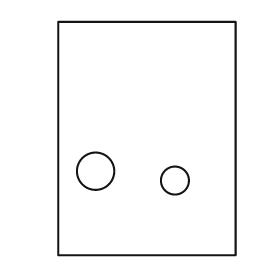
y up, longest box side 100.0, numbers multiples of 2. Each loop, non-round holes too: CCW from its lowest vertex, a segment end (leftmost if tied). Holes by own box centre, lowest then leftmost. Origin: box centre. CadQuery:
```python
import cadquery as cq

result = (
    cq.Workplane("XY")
    .moveTo(-38.0, -50.0)
    .lineTo(38.0, -50.0)
    .lineTo(38.0, 50.0)
    .lineTo(-38.0, 50.0)
    .close()
    .moveTo(12.0, -18.0)
    .circle(6.0)
    .moveTo(-22.0, -14.0)
    .circle(8.0)
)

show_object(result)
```